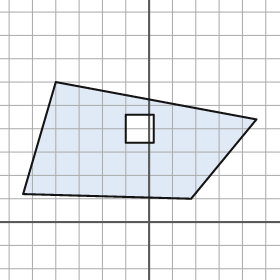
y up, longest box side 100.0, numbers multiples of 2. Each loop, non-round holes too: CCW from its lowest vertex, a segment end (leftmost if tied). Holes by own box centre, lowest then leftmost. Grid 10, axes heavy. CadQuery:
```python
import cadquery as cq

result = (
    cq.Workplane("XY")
    .moveTo(18.0, 10.0)
    .lineTo(46.0, 44.0)
    .lineTo(-40.0, 60.0)
    .lineTo(-54.0, 12.0)
    .close()
    .moveTo(-10.0, 34.0)
    .lineTo(2.0, 34.0)
    .lineTo(2.0, 46.0)
    .lineTo(-10.0, 46.0)
    .close()
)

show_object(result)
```